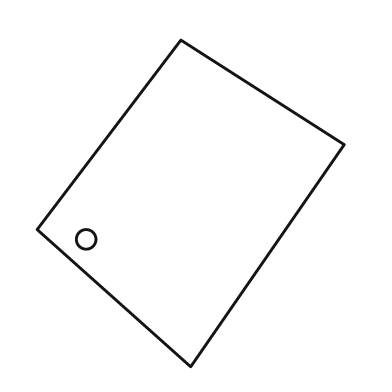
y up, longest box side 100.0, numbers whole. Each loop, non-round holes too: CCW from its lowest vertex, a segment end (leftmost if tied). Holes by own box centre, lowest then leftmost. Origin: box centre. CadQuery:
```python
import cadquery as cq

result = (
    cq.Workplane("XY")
    .moveTo(0.0, -50.0)
    .lineTo(47.0, 18.0)
    .lineTo(-3.0, 50.0)
    .lineTo(-47.0, -8.0)
    .close()
    .moveTo(-32.0, -11.0)
    .circle(3.0)
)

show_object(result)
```